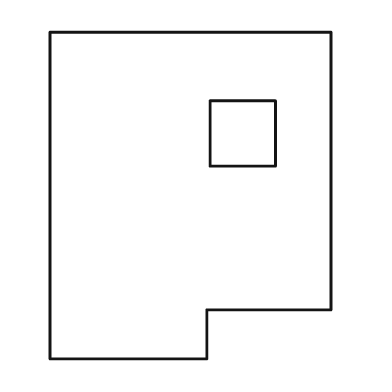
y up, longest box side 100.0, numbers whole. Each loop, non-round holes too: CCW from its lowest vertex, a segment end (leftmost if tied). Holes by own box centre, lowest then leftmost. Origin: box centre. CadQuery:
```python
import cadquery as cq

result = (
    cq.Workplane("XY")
    .moveTo(-43.0, -50.0)
    .lineTo(5.0, -50.0)
    .lineTo(5.0, -35.0)
    .lineTo(43.0, -35.0)
    .lineTo(43.0, 50.0)
    .lineTo(-43.0, 50.0)
    .close()
    .moveTo(6.0, 9.0)
    .lineTo(26.0, 9.0)
    .lineTo(26.0, 29.0)
    .lineTo(6.0, 29.0)
    .close()
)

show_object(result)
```